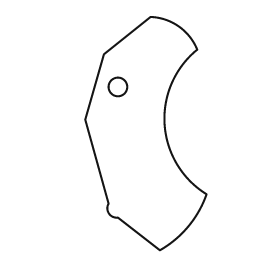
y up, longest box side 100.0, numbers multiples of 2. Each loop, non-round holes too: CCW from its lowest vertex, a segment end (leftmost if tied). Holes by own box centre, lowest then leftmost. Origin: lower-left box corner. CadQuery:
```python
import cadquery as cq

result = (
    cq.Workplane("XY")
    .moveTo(32.0, 0.0)
    .threePointArc((44.0, 10.0), (52.0, 24.0))
    .threePointArc((34.0, 54.0), (48.0, 86.0))
    .threePointArc((40.0, 96.0), (28.0, 100.0))
    .lineTo(8.0, 84.0)
    .lineTo(0.0, 56.0)
    .lineTo(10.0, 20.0)
    .threePointArc((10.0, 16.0), (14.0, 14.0))
    .close()
    .moveTo(14.0, 70.0)
    .circle(4.0)
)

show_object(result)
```